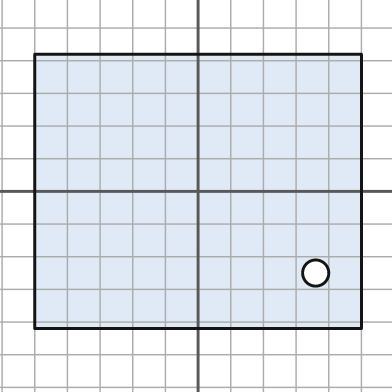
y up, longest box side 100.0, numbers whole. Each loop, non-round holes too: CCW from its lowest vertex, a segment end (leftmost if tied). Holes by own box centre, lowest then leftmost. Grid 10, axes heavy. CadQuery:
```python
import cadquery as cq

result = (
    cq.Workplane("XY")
    .moveTo(-50.0, -42.0)
    .lineTo(50.0, -42.0)
    .lineTo(50.0, 42.0)
    .lineTo(-50.0, 42.0)
    .close()
    .moveTo(36.0, -25.0)
    .circle(4.0)
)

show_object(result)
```